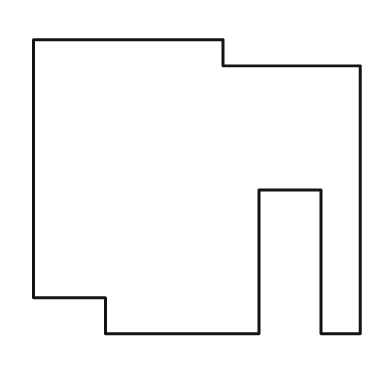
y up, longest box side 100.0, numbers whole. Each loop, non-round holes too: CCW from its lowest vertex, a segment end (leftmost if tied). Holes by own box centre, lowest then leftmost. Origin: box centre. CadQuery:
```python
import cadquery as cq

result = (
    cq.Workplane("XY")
    .moveTo(-28.0, -45.0)
    .lineTo(19.0, -45.0)
    .lineTo(19.0, -1.0)
    .lineTo(38.0, -1.0)
    .lineTo(38.0, -45.0)
    .lineTo(50.0, -45.0)
    .lineTo(50.0, 37.0)
    .lineTo(8.0, 37.0)
    .lineTo(8.0, 45.0)
    .lineTo(-50.0, 45.0)
    .lineTo(-50.0, -34.0)
    .lineTo(-28.0, -34.0)
    .close()
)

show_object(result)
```